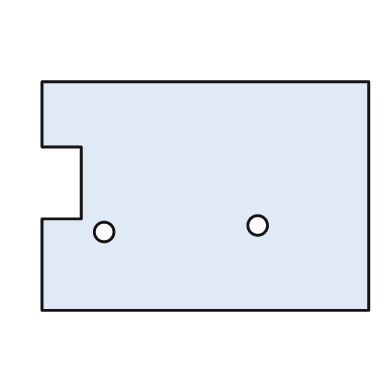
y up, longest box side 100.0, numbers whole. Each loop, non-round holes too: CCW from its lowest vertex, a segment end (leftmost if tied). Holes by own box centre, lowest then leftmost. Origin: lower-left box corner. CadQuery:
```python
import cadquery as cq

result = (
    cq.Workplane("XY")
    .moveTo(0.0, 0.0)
    .lineTo(100.0, 0.0)
    .lineTo(100.0, 70.0)
    .lineTo(0.0, 70.0)
    .lineTo(0.0, 50.0)
    .lineTo(12.0, 50.0)
    .lineTo(12.0, 28.0)
    .lineTo(0.0, 28.0)
    .close()
    .moveTo(19.0, 24.0)
    .circle(3.0)
    .moveTo(66.0, 26.0)
    .circle(3.0)
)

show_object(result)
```